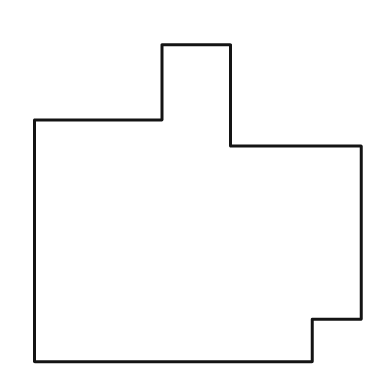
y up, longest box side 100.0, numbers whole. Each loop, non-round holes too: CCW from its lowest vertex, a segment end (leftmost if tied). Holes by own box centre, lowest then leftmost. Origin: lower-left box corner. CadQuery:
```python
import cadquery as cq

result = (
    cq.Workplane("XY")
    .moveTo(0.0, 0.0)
    .lineTo(85.0, 0.0)
    .lineTo(85.0, 13.0)
    .lineTo(100.0, 13.0)
    .lineTo(100.0, 66.0)
    .lineTo(60.0, 66.0)
    .lineTo(60.0, 97.0)
    .lineTo(39.0, 97.0)
    .lineTo(39.0, 74.0)
    .lineTo(0.0, 74.0)
    .close()
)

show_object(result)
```